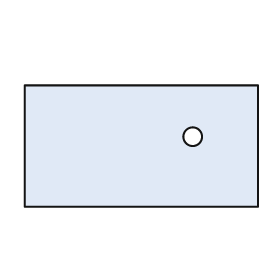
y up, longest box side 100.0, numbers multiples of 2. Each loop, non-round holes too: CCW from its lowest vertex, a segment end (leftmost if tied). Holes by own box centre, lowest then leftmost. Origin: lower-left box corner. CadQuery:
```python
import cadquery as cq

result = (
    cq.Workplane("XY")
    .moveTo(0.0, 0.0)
    .lineTo(100.0, 0.0)
    .lineTo(100.0, 52.0)
    .lineTo(0.0, 52.0)
    .close()
    .moveTo(72.0, 30.0)
    .circle(4.0)
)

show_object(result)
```